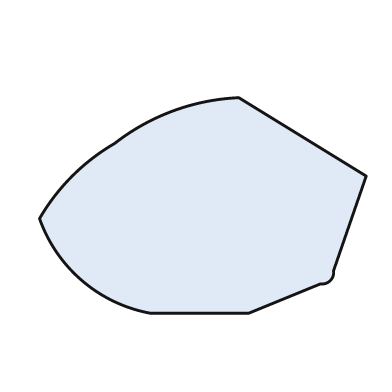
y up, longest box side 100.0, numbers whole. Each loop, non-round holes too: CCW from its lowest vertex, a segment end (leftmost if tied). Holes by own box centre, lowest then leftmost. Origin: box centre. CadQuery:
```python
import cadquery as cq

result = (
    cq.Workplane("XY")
    .moveTo(-16.0, -33.0)
    .lineTo(14.0, -33.0)
    .lineTo(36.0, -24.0)
    .threePointArc((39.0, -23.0), (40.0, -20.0))
    .lineTo(50.0, 9.0)
    .lineTo(11.0, 33.0)
    .threePointArc((-9.0, 29.0), (-27.0, 19.0))
    .threePointArc((-40.0, 9.0), (-50.0, -4.0))
    .threePointArc((-37.0, -23.0), (-16.0, -33.0))
    .close()
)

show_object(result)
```